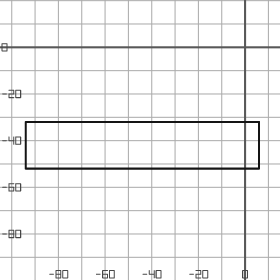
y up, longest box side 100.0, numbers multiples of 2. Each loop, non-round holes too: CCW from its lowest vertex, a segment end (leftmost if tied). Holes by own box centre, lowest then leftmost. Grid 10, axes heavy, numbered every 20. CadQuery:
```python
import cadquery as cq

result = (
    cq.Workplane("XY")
    .moveTo(-94.0, -52.0)
    .lineTo(6.0, -52.0)
    .lineTo(6.0, -32.0)
    .lineTo(-94.0, -32.0)
    .close()
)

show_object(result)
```